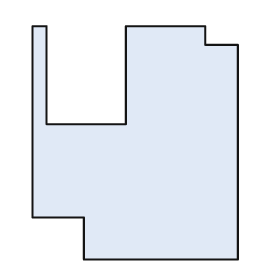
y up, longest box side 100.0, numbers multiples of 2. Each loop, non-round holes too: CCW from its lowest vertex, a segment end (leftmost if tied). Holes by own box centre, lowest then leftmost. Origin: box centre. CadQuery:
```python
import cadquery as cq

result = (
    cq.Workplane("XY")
    .moveTo(-22.0, -50.0)
    .lineTo(44.0, -50.0)
    .lineTo(44.0, 42.0)
    .lineTo(30.0, 42.0)
    .lineTo(30.0, 50.0)
    .lineTo(-4.0, 50.0)
    .lineTo(-4.0, 8.0)
    .lineTo(-38.0, 8.0)
    .lineTo(-38.0, 50.0)
    .lineTo(-44.0, 50.0)
    .lineTo(-44.0, -32.0)
    .lineTo(-22.0, -32.0)
    .close()
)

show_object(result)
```